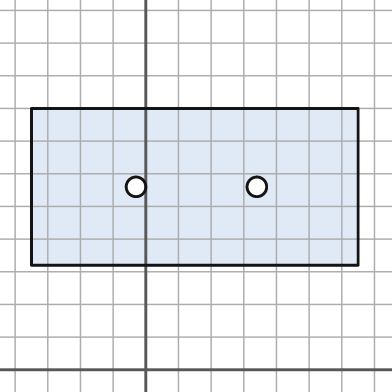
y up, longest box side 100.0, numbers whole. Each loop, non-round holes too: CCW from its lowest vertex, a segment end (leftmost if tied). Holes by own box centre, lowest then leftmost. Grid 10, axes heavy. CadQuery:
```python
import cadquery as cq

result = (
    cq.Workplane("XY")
    .moveTo(-35.0, 32.0)
    .lineTo(65.0, 32.0)
    .lineTo(65.0, 80.0)
    .lineTo(-35.0, 80.0)
    .close()
    .moveTo(-3.0, 56.0)
    .circle(3.0)
    .moveTo(34.0, 56.0)
    .circle(3.0)
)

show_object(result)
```